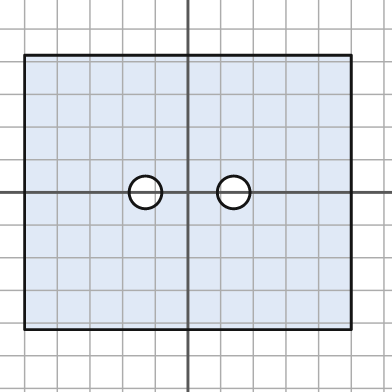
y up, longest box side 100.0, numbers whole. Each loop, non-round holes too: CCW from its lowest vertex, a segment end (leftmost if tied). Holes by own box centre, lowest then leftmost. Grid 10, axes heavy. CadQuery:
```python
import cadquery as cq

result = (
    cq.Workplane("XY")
    .moveTo(-50.0, -42.0)
    .lineTo(50.0, -42.0)
    .lineTo(50.0, 42.0)
    .lineTo(-50.0, 42.0)
    .close()
    .moveTo(-13.0, 0.0)
    .circle(5.0)
    .moveTo(14.0, 0.0)
    .circle(5.0)
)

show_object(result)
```